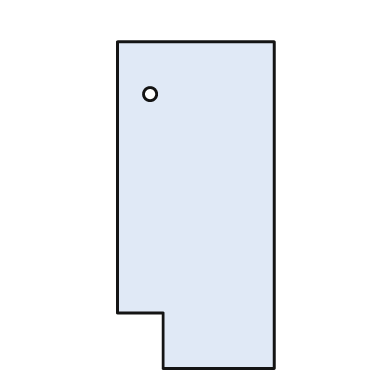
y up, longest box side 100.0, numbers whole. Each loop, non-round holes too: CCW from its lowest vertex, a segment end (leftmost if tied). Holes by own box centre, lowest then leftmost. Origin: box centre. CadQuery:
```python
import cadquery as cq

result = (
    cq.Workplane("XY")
    .moveTo(-10.0, -50.0)
    .lineTo(24.0, -50.0)
    .lineTo(24.0, 50.0)
    .lineTo(-24.0, 50.0)
    .lineTo(-24.0, -33.0)
    .lineTo(-10.0, -33.0)
    .close()
    .moveTo(-14.0, 34.0)
    .circle(2.0)
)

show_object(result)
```